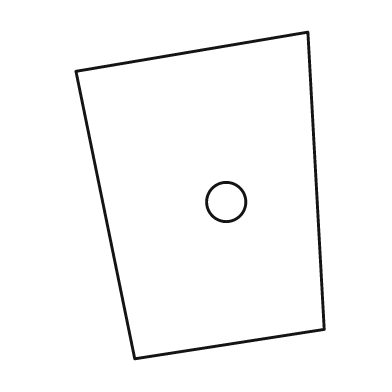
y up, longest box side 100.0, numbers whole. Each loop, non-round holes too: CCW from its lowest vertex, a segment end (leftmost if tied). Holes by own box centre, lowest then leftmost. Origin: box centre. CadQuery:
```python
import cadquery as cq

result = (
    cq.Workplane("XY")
    .moveTo(-20.0, -50.0)
    .lineTo(38.0, -41.0)
    .lineTo(33.0, 50.0)
    .lineTo(-38.0, 38.0)
    .close()
    .moveTo(8.0, -2.0)
    .circle(6.0)
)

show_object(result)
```